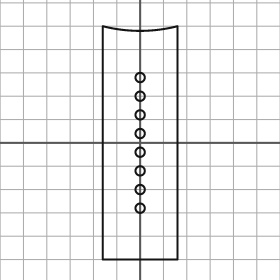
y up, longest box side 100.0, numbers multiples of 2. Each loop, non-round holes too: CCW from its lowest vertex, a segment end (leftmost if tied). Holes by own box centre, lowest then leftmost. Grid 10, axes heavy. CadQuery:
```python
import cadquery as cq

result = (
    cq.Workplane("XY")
    .moveTo(-16.0, -50.0)
    .lineTo(16.0, -50.0)
    .lineTo(16.0, 50.0)
    .threePointArc((0.0, 48.0), (-16.0, 50.0))
    .close()
    .moveTo(0.0, -28.0)
    .circle(2.0)
    .moveTo(0.0, -20.0)
    .circle(2.0)
    .moveTo(0.0, -12.0)
    .circle(2.0)
    .moveTo(0.0, -4.0)
    .circle(2.0)
    .moveTo(0.0, 4.0)
    .circle(2.0)
    .moveTo(0.0, 12.0)
    .circle(2.0)
    .moveTo(0.0, 20.0)
    .circle(2.0)
    .moveTo(0.0, 28.0)
    .circle(2.0)
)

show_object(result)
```